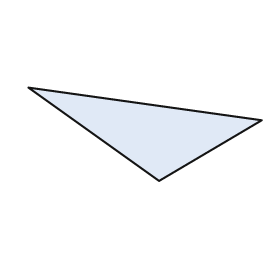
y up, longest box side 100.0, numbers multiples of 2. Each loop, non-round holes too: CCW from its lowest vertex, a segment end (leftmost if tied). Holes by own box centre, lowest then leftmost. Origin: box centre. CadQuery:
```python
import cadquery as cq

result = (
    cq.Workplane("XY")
    .moveTo(6.0, -20.0)
    .lineTo(50.0, 6.0)
    .lineTo(-50.0, 20.0)
    .close()
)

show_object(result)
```